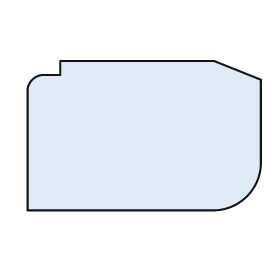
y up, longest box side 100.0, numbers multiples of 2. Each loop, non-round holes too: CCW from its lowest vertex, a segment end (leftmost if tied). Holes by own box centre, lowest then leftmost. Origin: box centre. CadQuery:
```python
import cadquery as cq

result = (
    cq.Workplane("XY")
    .moveTo(-50.0, -32.0)
    .lineTo(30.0, -32.0)
    .threePointArc((44.0, -26.0), (50.0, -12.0))
    .lineTo(50.0, 24.0)
    .lineTo(30.0, 32.0)
    .lineTo(-36.0, 32.0)
    .lineTo(-36.0, 26.0)
    .lineTo(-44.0, 26.0)
    .threePointArc((-48.0, 24.0), (-50.0, 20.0))
    .close()
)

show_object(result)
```